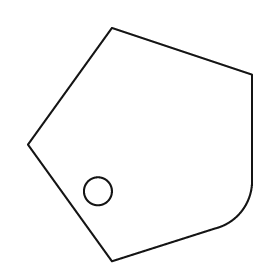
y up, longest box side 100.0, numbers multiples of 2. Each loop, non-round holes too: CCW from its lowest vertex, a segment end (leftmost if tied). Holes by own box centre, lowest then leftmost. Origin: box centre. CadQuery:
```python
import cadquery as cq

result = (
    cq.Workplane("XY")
    .moveTo(-12.0, -50.0)
    .lineTo(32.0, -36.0)
    .threePointArc((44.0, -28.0), (48.0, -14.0))
    .lineTo(48.0, 30.0)
    .lineTo(-12.0, 50.0)
    .lineTo(-48.0, 0.0)
    .close()
    .moveTo(-18.0, -20.0)
    .circle(6.0)
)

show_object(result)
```